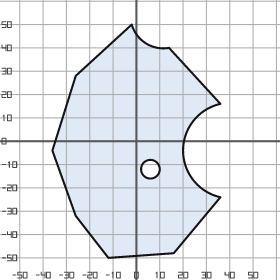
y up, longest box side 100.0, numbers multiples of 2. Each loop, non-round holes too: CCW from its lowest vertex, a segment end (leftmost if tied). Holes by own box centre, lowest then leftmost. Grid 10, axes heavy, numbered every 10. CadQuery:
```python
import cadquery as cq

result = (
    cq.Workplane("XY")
    .moveTo(-12.0, -50.0)
    .lineTo(16.0, -48.0)
    .lineTo(36.0, -24.0)
    .threePointArc((20.0, -4.0), (36.0, 16.0))
    .lineTo(14.0, 40.0)
    .threePointArc((4.0, 42.0), (-2.0, 50.0))
    .lineTo(-26.0, 28.0)
    .lineTo(-36.0, -4.0)
    .lineTo(-26.0, -32.0)
    .close()
    .moveTo(6.0, -12.0)
    .circle(4.0)
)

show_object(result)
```